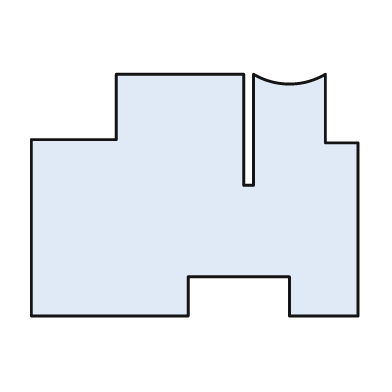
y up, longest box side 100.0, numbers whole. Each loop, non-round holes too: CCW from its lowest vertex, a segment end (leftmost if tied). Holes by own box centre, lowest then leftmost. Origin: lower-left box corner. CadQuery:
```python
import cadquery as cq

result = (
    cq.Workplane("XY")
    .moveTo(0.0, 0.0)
    .lineTo(48.0, 0.0)
    .lineTo(48.0, 12.0)
    .lineTo(79.0, 12.0)
    .lineTo(79.0, 0.0)
    .lineTo(100.0, 0.0)
    .lineTo(100.0, 53.0)
    .lineTo(90.0, 53.0)
    .lineTo(90.0, 74.0)
    .threePointArc((79.0, 71.0), (68.0, 74.0))
    .lineTo(68.0, 40.0)
    .lineTo(65.0, 40.0)
    .lineTo(65.0, 74.0)
    .lineTo(26.0, 74.0)
    .lineTo(26.0, 54.0)
    .lineTo(0.0, 54.0)
    .close()
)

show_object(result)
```